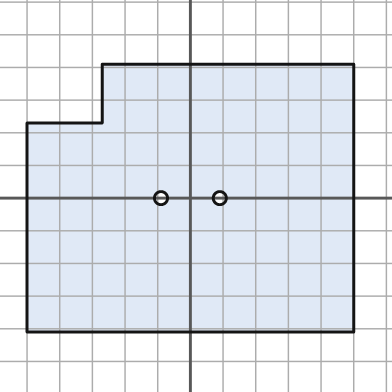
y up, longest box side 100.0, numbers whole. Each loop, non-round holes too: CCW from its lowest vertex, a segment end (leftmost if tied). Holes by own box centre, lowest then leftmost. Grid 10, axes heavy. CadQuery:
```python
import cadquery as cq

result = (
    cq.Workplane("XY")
    .moveTo(-50.0, -41.0)
    .lineTo(50.0, -41.0)
    .lineTo(50.0, 41.0)
    .lineTo(-27.0, 41.0)
    .lineTo(-27.0, 23.0)
    .lineTo(-50.0, 23.0)
    .close()
    .moveTo(-9.0, 0.0)
    .circle(2.0)
    .moveTo(9.0, 0.0)
    .circle(2.0)
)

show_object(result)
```